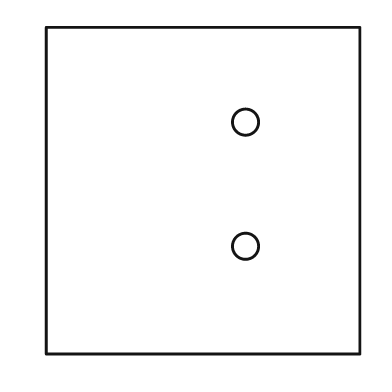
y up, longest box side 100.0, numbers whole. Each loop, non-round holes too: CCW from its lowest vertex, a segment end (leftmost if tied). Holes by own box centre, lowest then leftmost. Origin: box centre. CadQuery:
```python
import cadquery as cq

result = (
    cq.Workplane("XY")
    .moveTo(-48.0, -50.0)
    .lineTo(48.0, -50.0)
    .lineTo(48.0, 50.0)
    .lineTo(-48.0, 50.0)
    .close()
    .moveTo(13.0, -17.0)
    .circle(4.0)
    .moveTo(13.0, 21.0)
    .circle(4.0)
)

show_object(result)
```